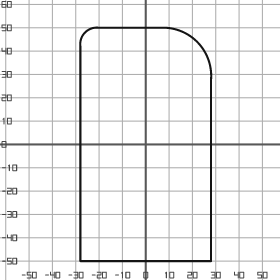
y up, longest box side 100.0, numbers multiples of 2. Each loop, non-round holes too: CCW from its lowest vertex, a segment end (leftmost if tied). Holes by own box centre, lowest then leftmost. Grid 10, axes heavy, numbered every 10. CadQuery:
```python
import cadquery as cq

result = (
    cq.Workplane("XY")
    .moveTo(-28.0, -50.0)
    .lineTo(28.0, -50.0)
    .lineTo(28.0, 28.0)
    .threePointArc((22.0, 44.0), (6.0, 50.0))
    .lineTo(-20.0, 50.0)
    .threePointArc((-26.0, 48.0), (-28.0, 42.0))
    .close()
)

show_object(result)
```